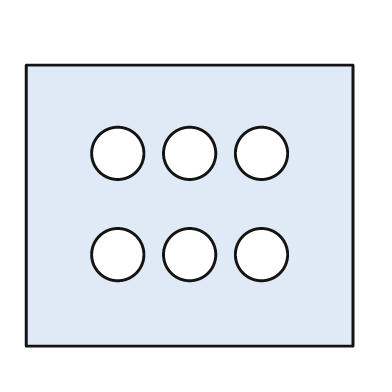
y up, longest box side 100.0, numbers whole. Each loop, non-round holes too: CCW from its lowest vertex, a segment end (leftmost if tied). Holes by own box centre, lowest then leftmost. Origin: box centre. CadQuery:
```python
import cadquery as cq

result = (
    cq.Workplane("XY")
    .moveTo(-50.0, -43.0)
    .lineTo(50.0, -43.0)
    .lineTo(50.0, 43.0)
    .lineTo(-50.0, 43.0)
    .close()
    .moveTo(-22.0, -15.0)
    .circle(8.0)
    .moveTo(0.0, -15.0)
    .circle(8.0)
    .moveTo(22.0, -15.0)
    .circle(8.0)
    .moveTo(-22.0, 16.0)
    .circle(8.0)
    .moveTo(0.0, 16.0)
    .circle(8.0)
    .moveTo(22.0, 16.0)
    .circle(8.0)
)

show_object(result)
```